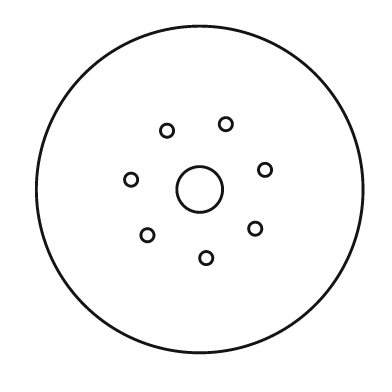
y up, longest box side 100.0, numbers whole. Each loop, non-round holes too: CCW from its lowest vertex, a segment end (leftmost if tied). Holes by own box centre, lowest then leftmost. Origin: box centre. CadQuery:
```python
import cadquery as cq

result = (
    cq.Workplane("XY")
    .moveTo(0.0, 0.0)
    .circle(50.0)
    .moveTo(2.0, -21.0)
    .circle(2.0)
    .moveTo(-16.0, -14.0)
    .circle(2.0)
    .moveTo(17.0, -12.0)
    .circle(2.0)
    .moveTo(0.0, 0.0)
    .circle(7.0)
    .moveTo(-21.0, 3.0)
    .circle(2.0)
    .moveTo(20.0, 6.0)
    .circle(2.0)
    .moveTo(-10.0, 18.0)
    .circle(2.0)
    .moveTo(8.0, 20.0)
    .circle(2.0)
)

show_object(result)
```